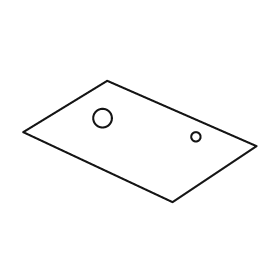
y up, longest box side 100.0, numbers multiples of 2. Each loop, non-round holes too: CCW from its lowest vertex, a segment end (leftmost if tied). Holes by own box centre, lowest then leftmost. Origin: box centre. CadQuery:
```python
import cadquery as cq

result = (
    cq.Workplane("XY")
    .moveTo(14.0, -26.0)
    .lineTo(50.0, -2.0)
    .lineTo(-14.0, 26.0)
    .lineTo(-50.0, 4.0)
    .close()
    .moveTo(24.0, 2.0)
    .circle(2.0)
    .moveTo(-16.0, 10.0)
    .circle(4.0)
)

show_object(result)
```